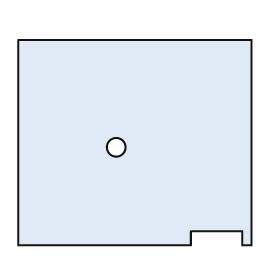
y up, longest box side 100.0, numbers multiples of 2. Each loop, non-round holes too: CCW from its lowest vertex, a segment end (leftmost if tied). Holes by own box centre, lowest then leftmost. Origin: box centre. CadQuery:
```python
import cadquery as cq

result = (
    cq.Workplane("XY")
    .moveTo(-50.0, -44.0)
    .lineTo(24.0, -44.0)
    .lineTo(24.0, -38.0)
    .lineTo(46.0, -38.0)
    .lineTo(46.0, -44.0)
    .lineTo(50.0, -44.0)
    .lineTo(50.0, 44.0)
    .lineTo(-50.0, 44.0)
    .close()
    .moveTo(-8.0, -2.0)
    .circle(4.0)
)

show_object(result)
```